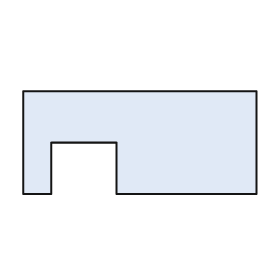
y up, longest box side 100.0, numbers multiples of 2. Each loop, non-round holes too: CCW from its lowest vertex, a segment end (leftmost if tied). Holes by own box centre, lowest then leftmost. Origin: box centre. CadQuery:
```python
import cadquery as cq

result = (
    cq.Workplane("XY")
    .moveTo(-50.0, -22.0)
    .lineTo(-38.0, -22.0)
    .lineTo(-38.0, 0.0)
    .lineTo(-10.0, 0.0)
    .lineTo(-10.0, -22.0)
    .lineTo(50.0, -22.0)
    .lineTo(50.0, 22.0)
    .lineTo(-50.0, 22.0)
    .close()
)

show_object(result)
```